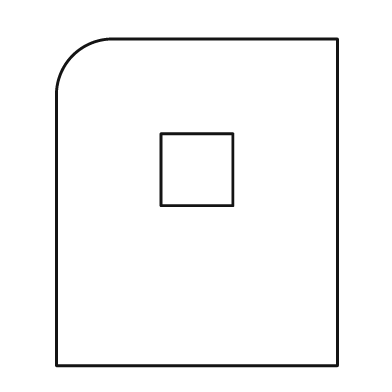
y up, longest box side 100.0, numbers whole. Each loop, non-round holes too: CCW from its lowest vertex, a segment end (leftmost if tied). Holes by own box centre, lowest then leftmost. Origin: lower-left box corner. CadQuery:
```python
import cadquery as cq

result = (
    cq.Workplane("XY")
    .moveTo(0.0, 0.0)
    .lineTo(86.0, 0.0)
    .lineTo(86.0, 100.0)
    .lineTo(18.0, 100.0)
    .threePointArc((5.0, 95.0), (0.0, 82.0))
    .close()
    .moveTo(32.0, 49.0)
    .lineTo(54.0, 49.0)
    .lineTo(54.0, 71.0)
    .lineTo(32.0, 71.0)
    .close()
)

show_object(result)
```